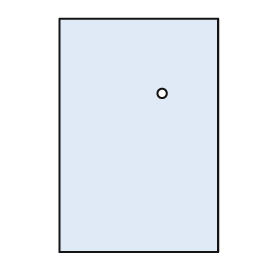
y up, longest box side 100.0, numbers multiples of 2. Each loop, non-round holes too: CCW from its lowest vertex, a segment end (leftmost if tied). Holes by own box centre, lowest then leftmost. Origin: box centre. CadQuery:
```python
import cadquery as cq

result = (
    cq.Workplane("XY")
    .moveTo(-34.0, -50.0)
    .lineTo(34.0, -50.0)
    .lineTo(34.0, 50.0)
    .lineTo(-34.0, 50.0)
    .close()
    .moveTo(10.0, 18.0)
    .circle(2.0)
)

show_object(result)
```